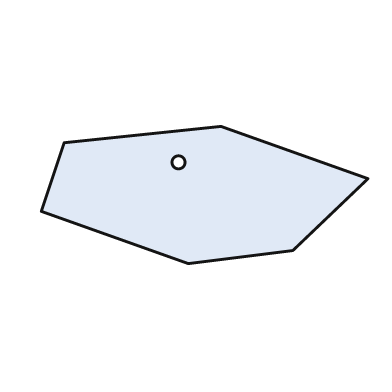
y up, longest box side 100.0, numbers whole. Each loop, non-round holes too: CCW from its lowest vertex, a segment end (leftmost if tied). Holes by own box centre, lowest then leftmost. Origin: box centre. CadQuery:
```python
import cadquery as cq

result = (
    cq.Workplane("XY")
    .moveTo(-5.0, -21.0)
    .lineTo(27.0, -17.0)
    .lineTo(50.0, 5.0)
    .lineTo(5.0, 21.0)
    .lineTo(-43.0, 16.0)
    .lineTo(-50.0, -5.0)
    .close()
    .moveTo(-8.0, 10.0)
    .circle(2.0)
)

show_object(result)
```